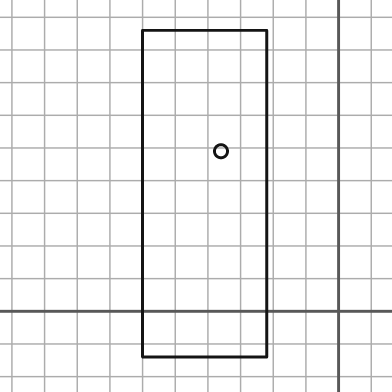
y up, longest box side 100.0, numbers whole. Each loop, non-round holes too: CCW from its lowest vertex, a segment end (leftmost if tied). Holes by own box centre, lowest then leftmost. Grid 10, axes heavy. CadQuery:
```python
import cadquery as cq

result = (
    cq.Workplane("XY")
    .moveTo(-60.0, -14.0)
    .lineTo(-22.0, -14.0)
    .lineTo(-22.0, 86.0)
    .lineTo(-60.0, 86.0)
    .close()
    .moveTo(-36.0, 49.0)
    .circle(2.0)
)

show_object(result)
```